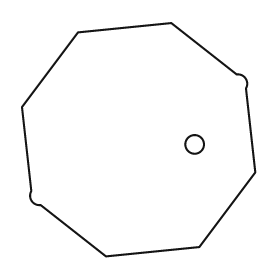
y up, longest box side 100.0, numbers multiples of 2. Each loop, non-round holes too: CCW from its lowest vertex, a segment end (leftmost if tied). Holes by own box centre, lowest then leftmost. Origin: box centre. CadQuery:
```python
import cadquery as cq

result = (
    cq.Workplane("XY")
    .moveTo(-14.0, -50.0)
    .lineTo(26.0, -46.0)
    .lineTo(50.0, -14.0)
    .lineTo(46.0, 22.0)
    .threePointArc((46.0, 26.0), (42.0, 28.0))
    .lineTo(14.0, 50.0)
    .lineTo(-26.0, 46.0)
    .lineTo(-50.0, 14.0)
    .lineTo(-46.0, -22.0)
    .threePointArc((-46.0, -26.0), (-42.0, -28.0))
    .close()
    .moveTo(24.0, -2.0)
    .circle(4.0)
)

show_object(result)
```